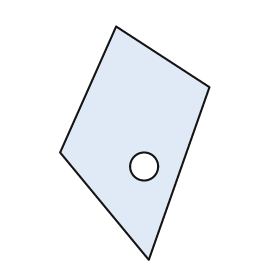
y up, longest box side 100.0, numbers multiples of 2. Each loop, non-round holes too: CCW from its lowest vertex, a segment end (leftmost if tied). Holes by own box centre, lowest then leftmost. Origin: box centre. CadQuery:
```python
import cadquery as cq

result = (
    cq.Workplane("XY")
    .moveTo(6.0, -50.0)
    .lineTo(32.0, 24.0)
    .lineTo(-8.0, 50.0)
    .lineTo(-32.0, -4.0)
    .close()
    .moveTo(4.0, -10.0)
    .circle(6.0)
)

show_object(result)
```